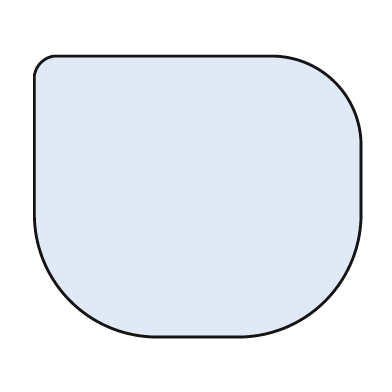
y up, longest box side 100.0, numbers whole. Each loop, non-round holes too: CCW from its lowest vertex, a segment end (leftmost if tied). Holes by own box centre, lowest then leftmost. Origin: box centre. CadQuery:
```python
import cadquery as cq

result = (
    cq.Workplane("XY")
    .moveTo(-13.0, -43.0)
    .lineTo(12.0, -43.0)
    .threePointArc((39.0, -32.0), (50.0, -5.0))
    .lineTo(50.0, 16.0)
    .threePointArc((42.0, 35.0), (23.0, 43.0))
    .lineTo(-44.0, 43.0)
    .threePointArc((-48.0, 41.0), (-50.0, 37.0))
    .lineTo(-50.0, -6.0)
    .threePointArc((-39.0, -32.0), (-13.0, -43.0))
    .close()
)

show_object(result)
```